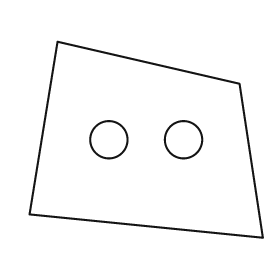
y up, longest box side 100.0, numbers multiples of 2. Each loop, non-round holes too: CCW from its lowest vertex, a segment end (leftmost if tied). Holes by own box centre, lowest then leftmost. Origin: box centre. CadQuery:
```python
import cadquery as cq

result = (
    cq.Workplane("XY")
    .moveTo(50.0, -42.0)
    .lineTo(40.0, 24.0)
    .lineTo(-38.0, 42.0)
    .lineTo(-50.0, -32.0)
    .close()
    .moveTo(-16.0, 0.0)
    .circle(8.0)
    .moveTo(16.0, 0.0)
    .circle(8.0)
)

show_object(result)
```